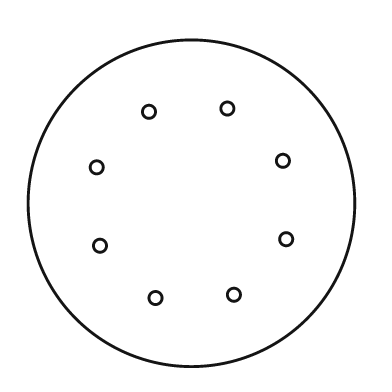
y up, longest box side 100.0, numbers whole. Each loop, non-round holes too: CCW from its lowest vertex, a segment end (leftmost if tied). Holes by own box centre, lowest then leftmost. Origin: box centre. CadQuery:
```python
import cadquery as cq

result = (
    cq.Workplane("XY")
    .moveTo(0.0, 0.0)
    .circle(50.0)
    .moveTo(-11.0, -29.0)
    .circle(2.0)
    .moveTo(13.0, -28.0)
    .circle(2.0)
    .moveTo(-28.0, -13.0)
    .circle(2.0)
    .moveTo(29.0, -11.0)
    .circle(2.0)
    .moveTo(-29.0, 11.0)
    .circle(2.0)
    .moveTo(28.0, 13.0)
    .circle(2.0)
    .moveTo(-13.0, 28.0)
    .circle(2.0)
    .moveTo(11.0, 29.0)
    .circle(2.0)
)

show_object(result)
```